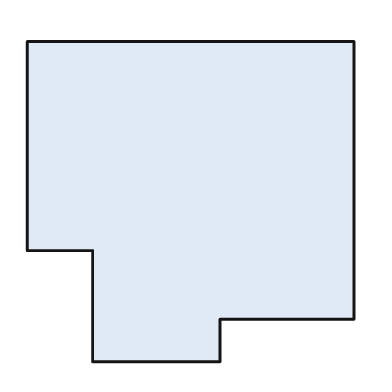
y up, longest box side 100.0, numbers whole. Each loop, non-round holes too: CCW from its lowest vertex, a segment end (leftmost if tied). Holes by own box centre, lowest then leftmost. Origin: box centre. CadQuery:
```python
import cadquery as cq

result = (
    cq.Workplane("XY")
    .moveTo(-30.0, -49.0)
    .lineTo(9.0, -49.0)
    .lineTo(9.0, -36.0)
    .lineTo(50.0, -36.0)
    .lineTo(50.0, 49.0)
    .lineTo(-50.0, 49.0)
    .lineTo(-50.0, -15.0)
    .lineTo(-30.0, -15.0)
    .close()
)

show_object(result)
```